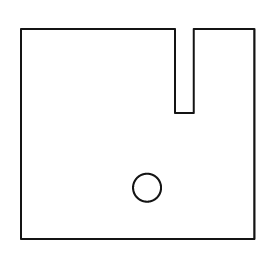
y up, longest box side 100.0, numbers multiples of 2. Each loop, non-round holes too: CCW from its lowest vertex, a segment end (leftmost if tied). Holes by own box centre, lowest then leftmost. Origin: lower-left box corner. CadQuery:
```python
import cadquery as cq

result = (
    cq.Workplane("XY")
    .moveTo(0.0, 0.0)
    .lineTo(100.0, 0.0)
    .lineTo(100.0, 90.0)
    .lineTo(74.0, 90.0)
    .lineTo(74.0, 54.0)
    .lineTo(66.0, 54.0)
    .lineTo(66.0, 90.0)
    .lineTo(0.0, 90.0)
    .close()
    .moveTo(54.0, 22.0)
    .circle(6.0)
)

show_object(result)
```